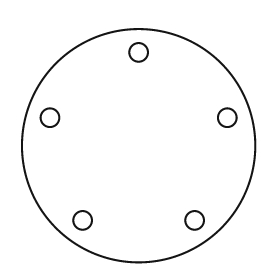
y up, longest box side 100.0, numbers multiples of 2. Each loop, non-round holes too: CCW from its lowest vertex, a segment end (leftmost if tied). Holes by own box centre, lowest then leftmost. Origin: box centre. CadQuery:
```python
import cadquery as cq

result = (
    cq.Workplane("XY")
    .moveTo(0.0, 0.0)
    .circle(50.0)
    .moveTo(-24.0, -32.0)
    .circle(4.0)
    .moveTo(24.0, -32.0)
    .circle(4.0)
    .moveTo(-38.0, 12.0)
    .circle(4.0)
    .moveTo(38.0, 12.0)
    .circle(4.0)
    .moveTo(0.0, 40.0)
    .circle(4.0)
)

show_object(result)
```